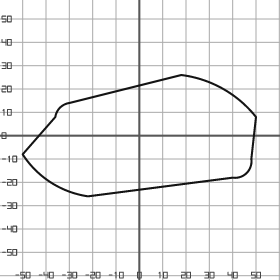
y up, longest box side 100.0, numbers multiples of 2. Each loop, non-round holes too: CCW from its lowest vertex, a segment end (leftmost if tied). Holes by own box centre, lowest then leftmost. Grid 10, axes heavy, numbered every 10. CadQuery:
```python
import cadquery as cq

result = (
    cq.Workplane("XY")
    .moveTo(-22.0, -26.0)
    .lineTo(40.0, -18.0)
    .threePointArc((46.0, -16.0), (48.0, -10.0))
    .lineTo(50.0, 8.0)
    .threePointArc((36.0, 20.0), (18.0, 26.0))
    .lineTo(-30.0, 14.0)
    .threePointArc((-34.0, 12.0), (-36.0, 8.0))
    .lineTo(-50.0, -8.0)
    .threePointArc((-38.0, -20.0), (-22.0, -26.0))
    .close()
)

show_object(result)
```